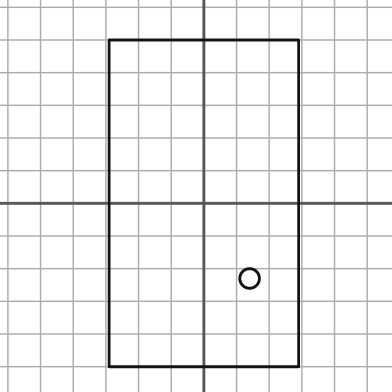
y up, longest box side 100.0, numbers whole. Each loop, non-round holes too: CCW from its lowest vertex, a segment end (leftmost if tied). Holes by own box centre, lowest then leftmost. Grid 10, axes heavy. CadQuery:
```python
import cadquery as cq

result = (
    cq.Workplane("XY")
    .moveTo(-29.0, -50.0)
    .lineTo(29.0, -50.0)
    .lineTo(29.0, 50.0)
    .lineTo(-29.0, 50.0)
    .close()
    .moveTo(14.0, -23.0)
    .circle(3.0)
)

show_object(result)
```